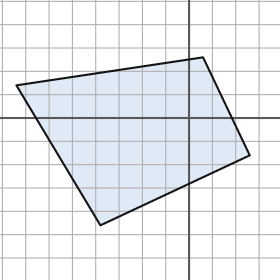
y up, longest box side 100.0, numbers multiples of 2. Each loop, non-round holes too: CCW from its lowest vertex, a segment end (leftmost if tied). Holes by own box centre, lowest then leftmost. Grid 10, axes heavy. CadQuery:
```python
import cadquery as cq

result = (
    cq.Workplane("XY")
    .moveTo(-38.0, -46.0)
    .lineTo(26.0, -16.0)
    .lineTo(6.0, 26.0)
    .lineTo(-74.0, 14.0)
    .close()
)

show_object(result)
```